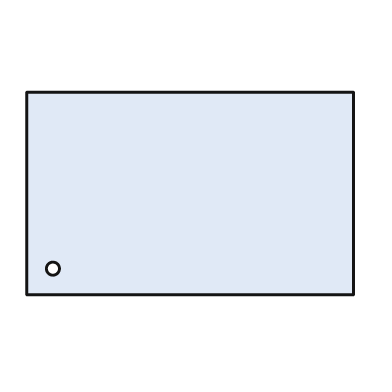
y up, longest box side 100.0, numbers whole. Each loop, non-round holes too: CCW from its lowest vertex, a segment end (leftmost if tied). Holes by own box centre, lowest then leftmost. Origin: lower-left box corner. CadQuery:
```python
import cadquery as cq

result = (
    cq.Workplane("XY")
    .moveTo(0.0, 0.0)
    .lineTo(100.0, 0.0)
    .lineTo(100.0, 62.0)
    .lineTo(0.0, 62.0)
    .close()
    .moveTo(8.0, 8.0)
    .circle(2.0)
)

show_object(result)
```